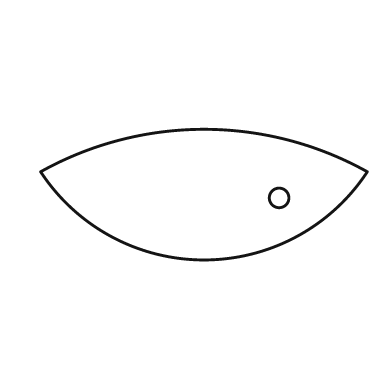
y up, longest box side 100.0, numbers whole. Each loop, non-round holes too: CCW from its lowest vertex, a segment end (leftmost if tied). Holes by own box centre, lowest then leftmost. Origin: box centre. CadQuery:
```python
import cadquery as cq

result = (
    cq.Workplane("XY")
    .moveTo(-50.0, 7.0)
    .threePointArc((0.0, -20.0), (50.0, 7.0))
    .threePointArc((0.0, 20.0), (-50.0, 7.0))
    .close()
    .moveTo(23.0, -1.0)
    .circle(3.0)
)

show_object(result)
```